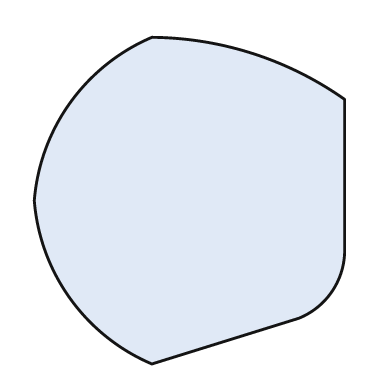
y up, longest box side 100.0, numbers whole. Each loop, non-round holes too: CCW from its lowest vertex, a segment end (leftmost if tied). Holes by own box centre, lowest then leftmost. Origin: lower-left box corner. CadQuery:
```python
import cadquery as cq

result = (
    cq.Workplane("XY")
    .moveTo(36.0, 0.0)
    .lineTo(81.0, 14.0)
    .threePointArc((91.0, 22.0), (95.0, 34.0))
    .lineTo(95.0, 81.0)
    .threePointArc((67.0, 95.0), (36.0, 100.0))
    .threePointArc((11.0, 80.0), (0.0, 50.0))
    .threePointArc((11.0, 20.0), (36.0, 0.0))
    .close()
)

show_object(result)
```